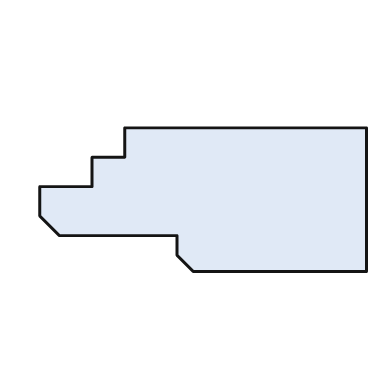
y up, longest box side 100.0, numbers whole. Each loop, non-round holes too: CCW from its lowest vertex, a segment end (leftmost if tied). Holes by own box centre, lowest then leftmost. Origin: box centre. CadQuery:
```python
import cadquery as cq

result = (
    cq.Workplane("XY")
    .moveTo(-3.0, -22.0)
    .lineTo(50.0, -22.0)
    .lineTo(50.0, 22.0)
    .lineTo(-24.0, 22.0)
    .lineTo(-24.0, 13.0)
    .lineTo(-34.0, 13.0)
    .lineTo(-34.0, 4.0)
    .lineTo(-50.0, 4.0)
    .lineTo(-50.0, -5.0)
    .lineTo(-44.0, -11.0)
    .lineTo(-8.0, -11.0)
    .lineTo(-8.0, -17.0)
    .close()
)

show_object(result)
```